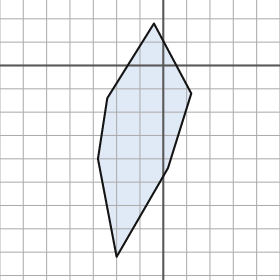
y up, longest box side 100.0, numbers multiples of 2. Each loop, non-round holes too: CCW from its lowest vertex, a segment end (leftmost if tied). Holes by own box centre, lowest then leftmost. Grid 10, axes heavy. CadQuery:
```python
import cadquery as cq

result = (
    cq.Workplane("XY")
    .moveTo(-20.0, -82.0)
    .lineTo(2.0, -44.0)
    .lineTo(12.0, -12.0)
    .lineTo(-4.0, 18.0)
    .lineTo(-24.0, -14.0)
    .lineTo(-28.0, -40.0)
    .close()
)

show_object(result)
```